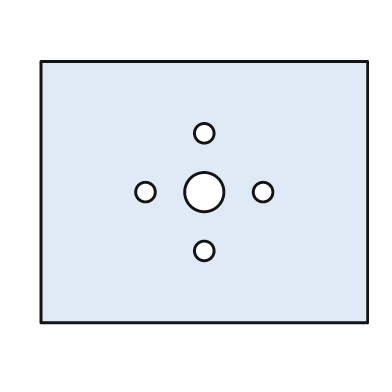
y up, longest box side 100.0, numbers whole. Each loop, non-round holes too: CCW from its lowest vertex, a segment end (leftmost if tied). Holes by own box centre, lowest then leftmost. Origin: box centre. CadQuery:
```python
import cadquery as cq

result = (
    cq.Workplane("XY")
    .moveTo(-50.0, -40.0)
    .lineTo(50.0, -40.0)
    .lineTo(50.0, 40.0)
    .lineTo(-50.0, 40.0)
    .close()
    .moveTo(0.0, -18.0)
    .circle(3.0)
    .moveTo(-18.0, 0.0)
    .circle(3.0)
    .moveTo(0.0, 0.0)
    .circle(6.0)
    .moveTo(18.0, 0.0)
    .circle(3.0)
    .moveTo(0.0, 18.0)
    .circle(3.0)
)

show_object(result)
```